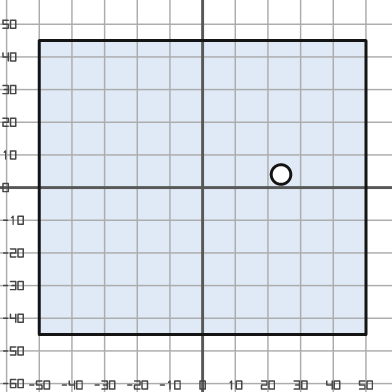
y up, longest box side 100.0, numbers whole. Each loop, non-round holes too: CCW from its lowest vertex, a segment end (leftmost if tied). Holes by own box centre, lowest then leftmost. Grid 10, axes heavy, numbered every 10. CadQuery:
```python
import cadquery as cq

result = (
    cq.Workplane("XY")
    .moveTo(-50.0, -45.0)
    .lineTo(50.0, -45.0)
    .lineTo(50.0, 45.0)
    .lineTo(-50.0, 45.0)
    .close()
    .moveTo(24.0, 4.0)
    .circle(3.0)
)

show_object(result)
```